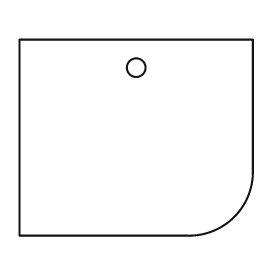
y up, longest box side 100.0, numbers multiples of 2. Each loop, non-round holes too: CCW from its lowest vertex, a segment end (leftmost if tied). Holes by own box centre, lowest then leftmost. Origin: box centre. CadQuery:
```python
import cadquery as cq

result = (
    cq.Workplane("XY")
    .moveTo(-50.0, -42.0)
    .lineTo(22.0, -42.0)
    .threePointArc((42.0, -34.0), (50.0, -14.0))
    .lineTo(50.0, 42.0)
    .lineTo(-50.0, 42.0)
    .close()
    .moveTo(0.0, 30.0)
    .circle(4.0)
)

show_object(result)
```